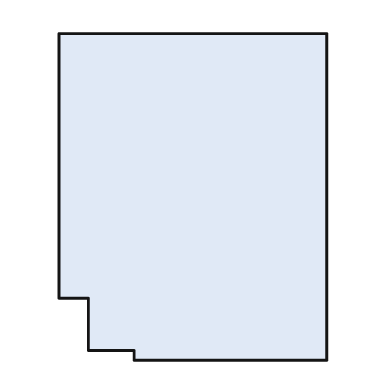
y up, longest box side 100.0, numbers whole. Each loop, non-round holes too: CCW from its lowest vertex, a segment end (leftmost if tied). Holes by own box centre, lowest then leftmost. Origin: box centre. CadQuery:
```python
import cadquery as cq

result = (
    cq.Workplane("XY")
    .moveTo(-18.0, -50.0)
    .lineTo(41.0, -50.0)
    .lineTo(41.0, 50.0)
    .lineTo(-41.0, 50.0)
    .lineTo(-41.0, -31.0)
    .lineTo(-32.0, -31.0)
    .lineTo(-32.0, -47.0)
    .lineTo(-18.0, -47.0)
    .close()
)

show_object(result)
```